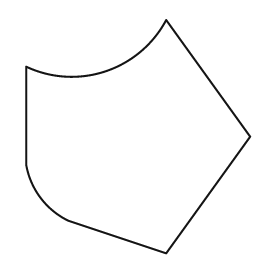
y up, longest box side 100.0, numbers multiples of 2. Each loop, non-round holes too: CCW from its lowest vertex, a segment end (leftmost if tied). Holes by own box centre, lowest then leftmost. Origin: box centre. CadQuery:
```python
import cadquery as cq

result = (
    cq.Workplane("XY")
    .moveTo(12.0, -50.0)
    .lineTo(48.0, 0.0)
    .lineTo(12.0, 50.0)
    .threePointArc((-14.0, 28.0), (-48.0, 30.0))
    .lineTo(-48.0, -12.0)
    .threePointArc((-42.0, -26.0), (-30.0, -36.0))
    .close()
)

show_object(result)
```